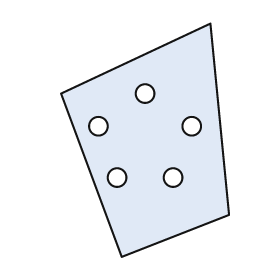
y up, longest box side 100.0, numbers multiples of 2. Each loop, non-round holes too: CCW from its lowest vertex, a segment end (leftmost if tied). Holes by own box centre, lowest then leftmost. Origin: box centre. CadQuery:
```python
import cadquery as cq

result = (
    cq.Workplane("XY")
    .moveTo(-10.0, -50.0)
    .lineTo(36.0, -32.0)
    .lineTo(28.0, 50.0)
    .lineTo(-36.0, 20.0)
    .close()
    .moveTo(-12.0, -16.0)
    .circle(4.0)
    .moveTo(12.0, -16.0)
    .circle(4.0)
    .moveTo(-20.0, 6.0)
    .circle(4.0)
    .moveTo(20.0, 6.0)
    .circle(4.0)
    .moveTo(0.0, 20.0)
    .circle(4.0)
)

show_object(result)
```